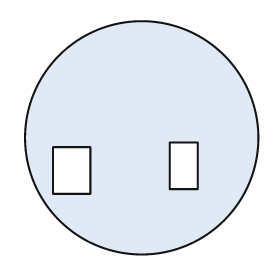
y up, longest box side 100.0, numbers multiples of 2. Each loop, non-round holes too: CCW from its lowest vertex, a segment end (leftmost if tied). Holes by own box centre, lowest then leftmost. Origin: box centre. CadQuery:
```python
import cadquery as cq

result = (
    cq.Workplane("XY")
    .moveTo(0.0, 0.0)
    .circle(50.0)
    .moveTo(-38.0, -24.0)
    .lineTo(-22.0, -24.0)
    .lineTo(-22.0, -4.0)
    .lineTo(-38.0, -4.0)
    .close()
    .moveTo(12.0, -22.0)
    .lineTo(24.0, -22.0)
    .lineTo(24.0, -2.0)
    .lineTo(12.0, -2.0)
    .close()
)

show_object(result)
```